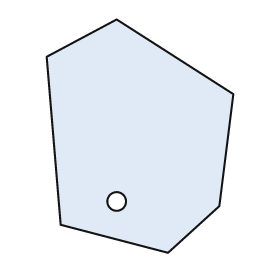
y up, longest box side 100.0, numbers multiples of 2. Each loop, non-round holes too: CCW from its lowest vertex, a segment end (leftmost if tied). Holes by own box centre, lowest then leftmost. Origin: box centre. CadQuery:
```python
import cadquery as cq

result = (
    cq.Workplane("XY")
    .moveTo(12.0, -50.0)
    .lineTo(34.0, -30.0)
    .lineTo(40.0, 18.0)
    .lineTo(-10.0, 50.0)
    .lineTo(-40.0, 34.0)
    .lineTo(-34.0, -38.0)
    .close()
    .moveTo(-10.0, -28.0)
    .circle(4.0)
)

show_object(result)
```